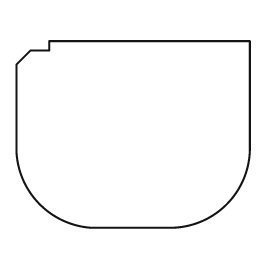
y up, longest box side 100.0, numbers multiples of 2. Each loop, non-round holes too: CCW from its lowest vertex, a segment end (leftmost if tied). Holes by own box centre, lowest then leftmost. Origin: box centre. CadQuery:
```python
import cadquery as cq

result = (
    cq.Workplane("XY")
    .moveTo(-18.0, -40.0)
    .lineTo(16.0, -40.0)
    .threePointArc((40.0, -30.0), (50.0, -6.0))
    .lineTo(50.0, 40.0)
    .lineTo(-36.0, 40.0)
    .lineTo(-36.0, 36.0)
    .lineTo(-44.0, 36.0)
    .lineTo(-50.0, 30.0)
    .lineTo(-50.0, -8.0)
    .threePointArc((-40.0, -30.0), (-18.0, -40.0))
    .close()
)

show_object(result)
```